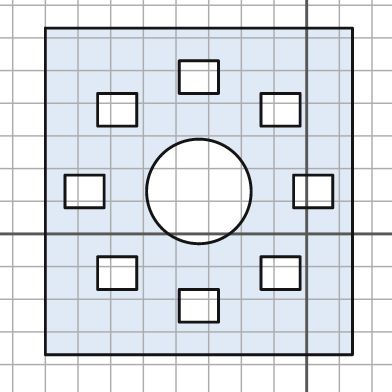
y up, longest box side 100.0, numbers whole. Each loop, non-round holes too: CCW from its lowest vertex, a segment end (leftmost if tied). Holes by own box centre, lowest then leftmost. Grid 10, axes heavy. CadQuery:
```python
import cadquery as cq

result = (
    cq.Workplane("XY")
    .moveTo(-80.0, -37.0)
    .lineTo(14.0, -37.0)
    .lineTo(14.0, 63.0)
    .lineTo(-80.0, 63.0)
    .close()
    .moveTo(-39.0, -27.0)
    .lineTo(-27.0, -27.0)
    .lineTo(-27.0, -17.0)
    .lineTo(-39.0, -17.0)
    .close()
    .moveTo(-64.0, -17.0)
    .lineTo(-52.0, -17.0)
    .lineTo(-52.0, -7.0)
    .lineTo(-64.0, -7.0)
    .close()
    .moveTo(-14.0, -17.0)
    .lineTo(-2.0, -17.0)
    .lineTo(-2.0, -7.0)
    .lineTo(-14.0, -7.0)
    .close()
    .moveTo(-74.0, 8.0)
    .lineTo(-62.0, 8.0)
    .lineTo(-62.0, 18.0)
    .lineTo(-74.0, 18.0)
    .close()
    .moveTo(-33.0, 13.0)
    .circle(16.0)
    .moveTo(-4.0, 8.0)
    .lineTo(8.0, 8.0)
    .lineTo(8.0, 18.0)
    .lineTo(-4.0, 18.0)
    .close()
    .moveTo(-64.0, 33.0)
    .lineTo(-52.0, 33.0)
    .lineTo(-52.0, 43.0)
    .lineTo(-64.0, 43.0)
    .close()
    .moveTo(-14.0, 33.0)
    .lineTo(-2.0, 33.0)
    .lineTo(-2.0, 43.0)
    .lineTo(-14.0, 43.0)
    .close()
    .moveTo(-39.0, 43.0)
    .lineTo(-27.0, 43.0)
    .lineTo(-27.0, 53.0)
    .lineTo(-39.0, 53.0)
    .close()
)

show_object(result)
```